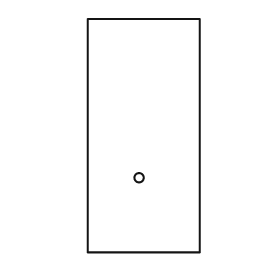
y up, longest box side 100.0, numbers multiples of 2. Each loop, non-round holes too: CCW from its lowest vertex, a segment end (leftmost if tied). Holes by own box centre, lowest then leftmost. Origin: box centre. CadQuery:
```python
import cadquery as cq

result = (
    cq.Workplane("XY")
    .moveTo(-24.0, -50.0)
    .lineTo(24.0, -50.0)
    .lineTo(24.0, 50.0)
    .lineTo(-24.0, 50.0)
    .close()
    .moveTo(-2.0, -18.0)
    .circle(2.0)
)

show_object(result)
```